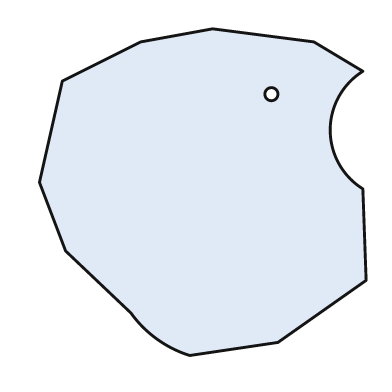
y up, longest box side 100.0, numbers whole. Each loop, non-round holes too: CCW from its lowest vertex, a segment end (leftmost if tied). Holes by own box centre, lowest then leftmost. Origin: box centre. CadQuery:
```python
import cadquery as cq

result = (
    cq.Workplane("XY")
    .moveTo(-4.0, -50.0)
    .lineTo(23.0, -46.0)
    .lineTo(50.0, -27.0)
    .lineTo(49.0, 1.0)
    .threePointArc((39.0, 19.0), (49.0, 37.0))
    .lineTo(34.0, 46.0)
    .lineTo(3.0, 50.0)
    .lineTo(-19.0, 46.0)
    .lineTo(-43.0, 34.0)
    .lineTo(-50.0, 3.0)
    .lineTo(-42.0, -18.0)
    .lineTo(-22.0, -37.0)
    .threePointArc((-14.0, -45.0), (-4.0, -50.0))
    .close()
    .moveTo(21.0, 30.0)
    .circle(2.0)
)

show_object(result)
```